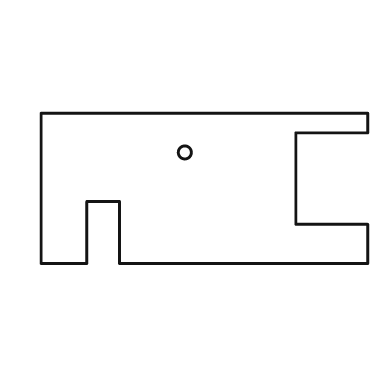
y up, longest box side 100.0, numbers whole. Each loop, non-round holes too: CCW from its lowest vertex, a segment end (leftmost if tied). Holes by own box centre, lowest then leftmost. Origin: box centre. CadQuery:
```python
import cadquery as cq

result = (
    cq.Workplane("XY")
    .moveTo(-50.0, -23.0)
    .lineTo(-36.0, -23.0)
    .lineTo(-36.0, -4.0)
    .lineTo(-26.0, -4.0)
    .lineTo(-26.0, -23.0)
    .lineTo(50.0, -23.0)
    .lineTo(50.0, -11.0)
    .lineTo(28.0, -11.0)
    .lineTo(28.0, 17.0)
    .lineTo(50.0, 17.0)
    .lineTo(50.0, 23.0)
    .lineTo(-50.0, 23.0)
    .close()
    .moveTo(-6.0, 11.0)
    .circle(2.0)
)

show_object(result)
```